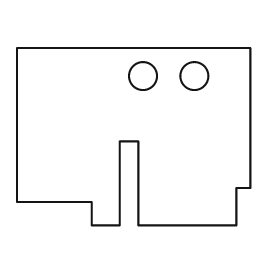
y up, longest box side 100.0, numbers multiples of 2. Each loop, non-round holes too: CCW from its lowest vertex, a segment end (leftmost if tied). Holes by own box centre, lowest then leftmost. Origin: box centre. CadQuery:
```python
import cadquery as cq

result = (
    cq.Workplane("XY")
    .moveTo(-18.0, -38.0)
    .lineTo(-6.0, -38.0)
    .lineTo(-6.0, -2.0)
    .lineTo(2.0, -2.0)
    .lineTo(2.0, -38.0)
    .lineTo(44.0, -38.0)
    .lineTo(44.0, -22.0)
    .lineTo(50.0, -22.0)
    .lineTo(50.0, 38.0)
    .lineTo(-50.0, 38.0)
    .lineTo(-50.0, -28.0)
    .lineTo(-18.0, -28.0)
    .close()
    .moveTo(4.0, 26.0)
    .circle(6.0)
    .moveTo(26.0, 26.0)
    .circle(6.0)
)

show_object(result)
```